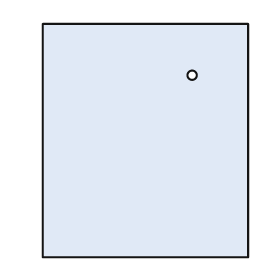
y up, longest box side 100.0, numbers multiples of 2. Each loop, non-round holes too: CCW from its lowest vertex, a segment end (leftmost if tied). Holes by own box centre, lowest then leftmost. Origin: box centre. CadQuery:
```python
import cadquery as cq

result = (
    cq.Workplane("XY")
    .moveTo(-44.0, -50.0)
    .lineTo(44.0, -50.0)
    .lineTo(44.0, 50.0)
    .lineTo(-44.0, 50.0)
    .close()
    .moveTo(20.0, 28.0)
    .circle(2.0)
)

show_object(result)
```